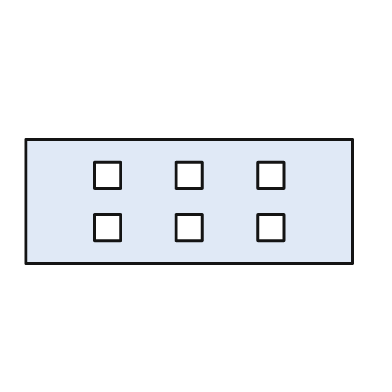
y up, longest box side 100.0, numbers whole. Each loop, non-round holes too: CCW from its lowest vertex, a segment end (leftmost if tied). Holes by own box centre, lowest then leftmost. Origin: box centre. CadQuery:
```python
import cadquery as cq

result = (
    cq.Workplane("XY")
    .moveTo(-50.0, -19.0)
    .lineTo(50.0, -19.0)
    .lineTo(50.0, 19.0)
    .lineTo(-50.0, 19.0)
    .close()
    .moveTo(-29.0, -12.0)
    .lineTo(-21.0, -12.0)
    .lineTo(-21.0, -4.0)
    .lineTo(-29.0, -4.0)
    .close()
    .moveTo(-4.0, -12.0)
    .lineTo(4.0, -12.0)
    .lineTo(4.0, -4.0)
    .lineTo(-4.0, -4.0)
    .close()
    .moveTo(21.0, -12.0)
    .lineTo(29.0, -12.0)
    .lineTo(29.0, -4.0)
    .lineTo(21.0, -4.0)
    .close()
    .moveTo(-29.0, 4.0)
    .lineTo(-21.0, 4.0)
    .lineTo(-21.0, 12.0)
    .lineTo(-29.0, 12.0)
    .close()
    .moveTo(-4.0, 4.0)
    .lineTo(4.0, 4.0)
    .lineTo(4.0, 12.0)
    .lineTo(-4.0, 12.0)
    .close()
    .moveTo(21.0, 4.0)
    .lineTo(29.0, 4.0)
    .lineTo(29.0, 12.0)
    .lineTo(21.0, 12.0)
    .close()
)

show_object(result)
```